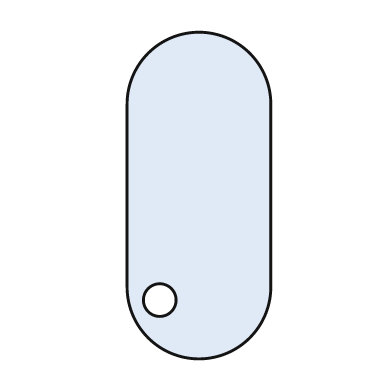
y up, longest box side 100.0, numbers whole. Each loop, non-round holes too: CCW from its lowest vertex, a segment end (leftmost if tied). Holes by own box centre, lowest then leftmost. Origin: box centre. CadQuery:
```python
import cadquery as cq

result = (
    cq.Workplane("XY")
    .moveTo(-22.0, -28.0)
    .threePointArc((0.0, -50.0), (22.0, -28.0))
    .lineTo(22.0, 28.0)
    .threePointArc((0.0, 50.0), (-22.0, 28.0))
    .close()
    .moveTo(-12.0, -32.0)
    .circle(5.0)
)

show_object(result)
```